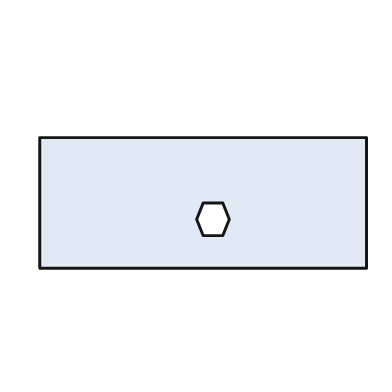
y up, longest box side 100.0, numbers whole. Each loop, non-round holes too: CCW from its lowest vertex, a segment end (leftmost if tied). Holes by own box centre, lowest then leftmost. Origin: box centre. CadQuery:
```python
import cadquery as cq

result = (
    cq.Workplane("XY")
    .moveTo(-50.0, -20.0)
    .lineTo(50.0, -20.0)
    .lineTo(50.0, 20.0)
    .lineTo(-50.0, 20.0)
    .close()
    .moveTo(0.0, -10.0)
    .lineTo(6.0, -10.0)
    .lineTo(8.0, -5.0)
    .lineTo(6.0, 0.0)
    .lineTo(0.0, 0.0)
    .lineTo(-2.0, -5.0)
    .close()
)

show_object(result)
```